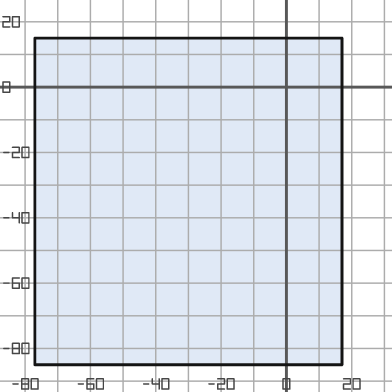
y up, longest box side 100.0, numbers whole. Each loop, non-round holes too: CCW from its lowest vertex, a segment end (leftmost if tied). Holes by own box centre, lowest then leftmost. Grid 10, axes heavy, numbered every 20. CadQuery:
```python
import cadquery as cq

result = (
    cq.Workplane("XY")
    .moveTo(-77.0, -85.0)
    .lineTo(17.0, -85.0)
    .lineTo(17.0, 15.0)
    .lineTo(-77.0, 15.0)
    .close()
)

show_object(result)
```